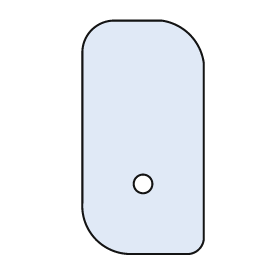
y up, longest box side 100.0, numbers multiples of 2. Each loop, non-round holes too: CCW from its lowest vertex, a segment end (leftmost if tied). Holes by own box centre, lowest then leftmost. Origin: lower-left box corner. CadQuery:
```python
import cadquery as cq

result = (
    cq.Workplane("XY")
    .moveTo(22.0, 0.0)
    .lineTo(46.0, 0.0)
    .threePointArc((50.0, 2.0), (52.0, 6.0))
    .lineTo(52.0, 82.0)
    .threePointArc((46.0, 94.0), (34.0, 100.0))
    .lineTo(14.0, 100.0)
    .threePointArc((4.0, 96.0), (0.0, 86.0))
    .lineTo(0.0, 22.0)
    .threePointArc((6.0, 6.0), (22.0, 0.0))
    .close()
    .moveTo(26.0, 30.0)
    .circle(4.0)
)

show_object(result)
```